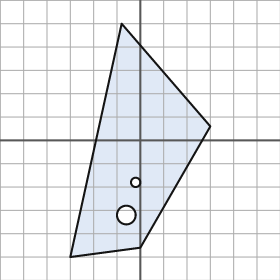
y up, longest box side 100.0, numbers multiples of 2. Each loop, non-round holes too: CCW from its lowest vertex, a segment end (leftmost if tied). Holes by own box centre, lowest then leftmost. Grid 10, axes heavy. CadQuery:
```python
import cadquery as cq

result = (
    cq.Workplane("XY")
    .moveTo(-30.0, -50.0)
    .lineTo(0.0, -46.0)
    .lineTo(30.0, 6.0)
    .lineTo(-8.0, 50.0)
    .close()
    .moveTo(-6.0, -32.0)
    .circle(4.0)
    .moveTo(-2.0, -18.0)
    .circle(2.0)
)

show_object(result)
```